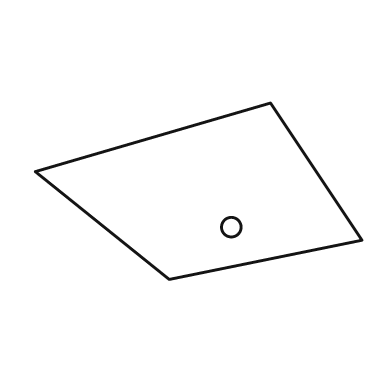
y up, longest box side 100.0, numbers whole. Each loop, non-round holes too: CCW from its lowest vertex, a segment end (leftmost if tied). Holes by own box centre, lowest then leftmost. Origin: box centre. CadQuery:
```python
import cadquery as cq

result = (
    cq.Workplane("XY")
    .moveTo(-9.0, -27.0)
    .lineTo(50.0, -15.0)
    .lineTo(22.0, 27.0)
    .lineTo(-50.0, 6.0)
    .close()
    .moveTo(10.0, -11.0)
    .circle(3.0)
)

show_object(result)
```